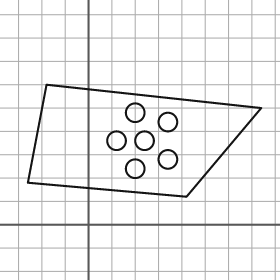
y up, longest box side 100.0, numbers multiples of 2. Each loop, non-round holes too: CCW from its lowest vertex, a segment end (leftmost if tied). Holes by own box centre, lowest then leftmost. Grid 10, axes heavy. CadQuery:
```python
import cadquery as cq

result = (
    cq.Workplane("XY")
    .moveTo(42.0, 12.0)
    .lineTo(74.0, 50.0)
    .lineTo(-18.0, 60.0)
    .lineTo(-26.0, 18.0)
    .close()
    .moveTo(20.0, 24.0)
    .circle(4.0)
    .moveTo(34.0, 28.0)
    .circle(4.0)
    .moveTo(12.0, 36.0)
    .circle(4.0)
    .moveTo(24.0, 36.0)
    .circle(4.0)
    .moveTo(34.0, 44.0)
    .circle(4.0)
    .moveTo(20.0, 48.0)
    .circle(4.0)
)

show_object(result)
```